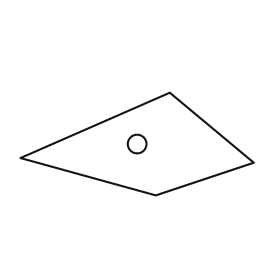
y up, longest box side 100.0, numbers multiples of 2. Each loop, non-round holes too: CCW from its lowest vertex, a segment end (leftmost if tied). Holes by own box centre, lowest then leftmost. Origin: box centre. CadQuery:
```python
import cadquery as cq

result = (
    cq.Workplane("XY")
    .moveTo(8.0, -22.0)
    .lineTo(50.0, -8.0)
    .lineTo(14.0, 22.0)
    .lineTo(-50.0, -6.0)
    .close()
    .moveTo(0.0, 0.0)
    .circle(4.0)
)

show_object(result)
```